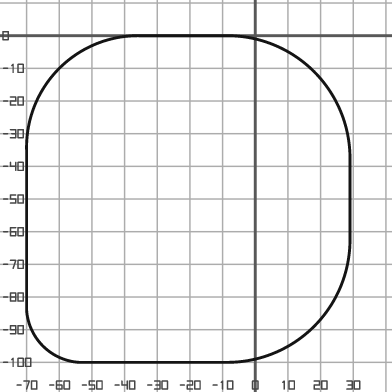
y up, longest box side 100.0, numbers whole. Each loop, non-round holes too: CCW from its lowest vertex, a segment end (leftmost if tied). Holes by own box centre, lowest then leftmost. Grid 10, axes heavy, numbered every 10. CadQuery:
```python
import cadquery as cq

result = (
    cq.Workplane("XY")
    .moveTo(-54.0, -100.0)
    .lineTo(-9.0, -100.0)
    .threePointArc((18.0, -89.0), (29.0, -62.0))
    .lineTo(29.0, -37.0)
    .threePointArc((18.0, -11.0), (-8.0, 0.0))
    .lineTo(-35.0, 0.0)
    .threePointArc((-60.0, -10.0), (-70.0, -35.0))
    .lineTo(-70.0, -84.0)
    .threePointArc((-65.0, -95.0), (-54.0, -100.0))
    .close()
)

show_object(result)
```